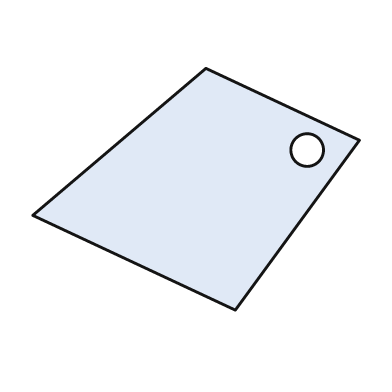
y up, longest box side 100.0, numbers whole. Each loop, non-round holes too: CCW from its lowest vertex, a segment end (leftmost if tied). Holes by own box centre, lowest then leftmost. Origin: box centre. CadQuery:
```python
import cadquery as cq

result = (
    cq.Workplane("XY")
    .moveTo(12.0, -37.0)
    .lineTo(50.0, 15.0)
    .lineTo(3.0, 37.0)
    .lineTo(-50.0, -8.0)
    .close()
    .moveTo(34.0, 12.0)
    .circle(5.0)
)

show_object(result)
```